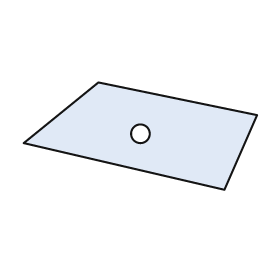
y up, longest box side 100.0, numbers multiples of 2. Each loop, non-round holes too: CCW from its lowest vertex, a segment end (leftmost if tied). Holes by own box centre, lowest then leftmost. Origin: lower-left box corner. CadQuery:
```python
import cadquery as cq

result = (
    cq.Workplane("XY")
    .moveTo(86.0, 0.0)
    .lineTo(100.0, 32.0)
    .lineTo(32.0, 46.0)
    .lineTo(0.0, 20.0)
    .close()
    .moveTo(50.0, 24.0)
    .circle(4.0)
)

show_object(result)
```